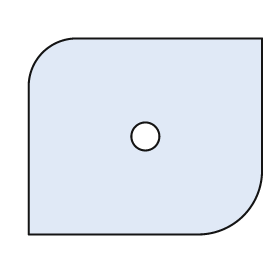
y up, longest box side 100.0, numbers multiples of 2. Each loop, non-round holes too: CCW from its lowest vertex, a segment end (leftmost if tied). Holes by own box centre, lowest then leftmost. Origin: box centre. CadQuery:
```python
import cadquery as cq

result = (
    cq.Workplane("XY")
    .moveTo(-50.0, -42.0)
    .lineTo(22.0, -42.0)
    .threePointArc((42.0, -34.0), (50.0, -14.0))
    .lineTo(50.0, 42.0)
    .lineTo(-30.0, 42.0)
    .threePointArc((-44.0, 36.0), (-50.0, 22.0))
    .close()
    .moveTo(0.0, 0.0)
    .circle(6.0)
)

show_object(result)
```